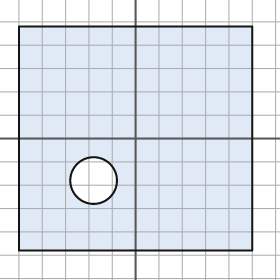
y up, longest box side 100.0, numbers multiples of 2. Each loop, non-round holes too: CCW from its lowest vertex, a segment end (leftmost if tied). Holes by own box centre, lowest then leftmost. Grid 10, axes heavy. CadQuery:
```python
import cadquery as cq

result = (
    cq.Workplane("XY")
    .moveTo(-50.0, -48.0)
    .lineTo(50.0, -48.0)
    .lineTo(50.0, 48.0)
    .lineTo(-50.0, 48.0)
    .close()
    .moveTo(-18.0, -18.0)
    .circle(10.0)
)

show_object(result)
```